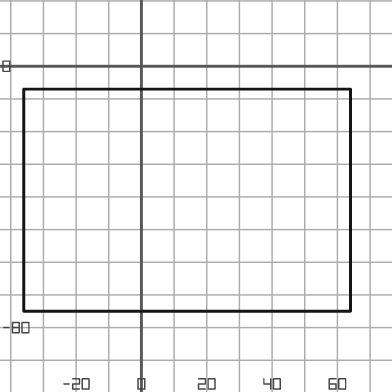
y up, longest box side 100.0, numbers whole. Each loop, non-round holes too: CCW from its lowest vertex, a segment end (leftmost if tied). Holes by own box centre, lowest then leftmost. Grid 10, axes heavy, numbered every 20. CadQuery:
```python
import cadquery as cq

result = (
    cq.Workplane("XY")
    .moveTo(-36.0, -75.0)
    .lineTo(64.0, -75.0)
    .lineTo(64.0, -7.0)
    .lineTo(-36.0, -7.0)
    .close()
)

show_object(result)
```